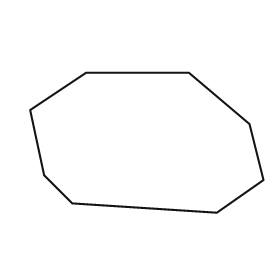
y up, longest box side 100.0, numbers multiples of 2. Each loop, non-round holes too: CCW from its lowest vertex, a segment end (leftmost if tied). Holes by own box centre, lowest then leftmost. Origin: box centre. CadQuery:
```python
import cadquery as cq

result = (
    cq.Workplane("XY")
    .moveTo(30.0, -30.0)
    .lineTo(50.0, -16.0)
    .lineTo(44.0, 8.0)
    .lineTo(18.0, 30.0)
    .lineTo(-26.0, 30.0)
    .lineTo(-50.0, 14.0)
    .lineTo(-44.0, -14.0)
    .lineTo(-32.0, -26.0)
    .close()
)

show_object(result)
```